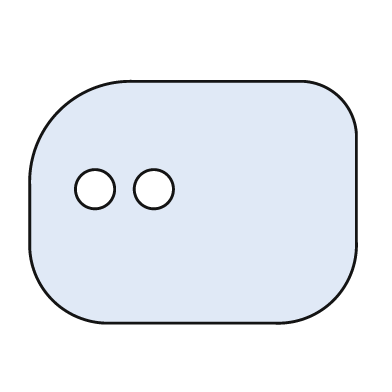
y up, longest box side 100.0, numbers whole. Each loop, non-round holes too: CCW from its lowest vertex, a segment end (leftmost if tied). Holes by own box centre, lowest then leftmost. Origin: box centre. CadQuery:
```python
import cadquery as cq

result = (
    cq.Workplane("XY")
    .moveTo(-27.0, -37.0)
    .lineTo(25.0, -37.0)
    .threePointArc((43.0, -30.0), (50.0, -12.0))
    .lineTo(50.0, 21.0)
    .threePointArc((45.0, 32.0), (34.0, 37.0))
    .lineTo(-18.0, 37.0)
    .threePointArc((-41.0, 28.0), (-50.0, 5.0))
    .lineTo(-50.0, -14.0)
    .threePointArc((-43.0, -30.0), (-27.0, -37.0))
    .close()
    .moveTo(-30.0, 4.0)
    .circle(6.0)
    .moveTo(-12.0, 4.0)
    .circle(6.0)
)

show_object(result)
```